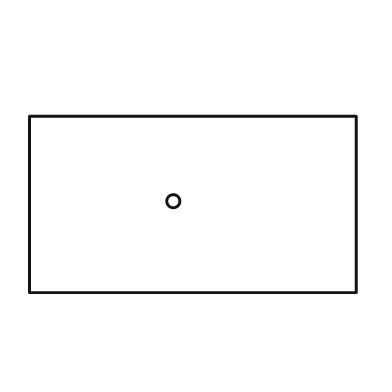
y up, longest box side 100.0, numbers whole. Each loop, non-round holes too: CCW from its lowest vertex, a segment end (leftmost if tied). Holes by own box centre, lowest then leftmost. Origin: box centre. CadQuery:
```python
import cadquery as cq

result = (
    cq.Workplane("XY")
    .moveTo(-50.0, -27.0)
    .lineTo(50.0, -27.0)
    .lineTo(50.0, 27.0)
    .lineTo(-50.0, 27.0)
    .close()
    .moveTo(-6.0, 1.0)
    .circle(2.0)
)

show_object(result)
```